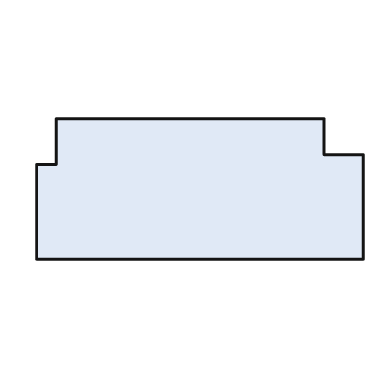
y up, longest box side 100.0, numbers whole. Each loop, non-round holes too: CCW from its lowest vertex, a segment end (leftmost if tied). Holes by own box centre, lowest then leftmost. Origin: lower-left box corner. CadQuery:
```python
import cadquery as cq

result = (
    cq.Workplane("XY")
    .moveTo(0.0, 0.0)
    .lineTo(100.0, 0.0)
    .lineTo(100.0, 32.0)
    .lineTo(88.0, 32.0)
    .lineTo(88.0, 43.0)
    .lineTo(6.0, 43.0)
    .lineTo(6.0, 29.0)
    .lineTo(0.0, 29.0)
    .close()
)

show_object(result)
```